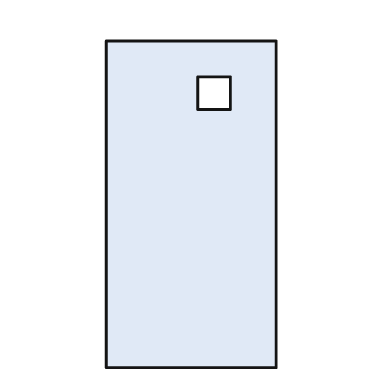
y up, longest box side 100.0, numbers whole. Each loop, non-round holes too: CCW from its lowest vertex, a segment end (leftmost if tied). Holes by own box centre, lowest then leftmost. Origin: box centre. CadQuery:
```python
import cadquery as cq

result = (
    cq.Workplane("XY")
    .moveTo(-26.0, -50.0)
    .lineTo(26.0, -50.0)
    .lineTo(26.0, 50.0)
    .lineTo(-26.0, 50.0)
    .close()
    .moveTo(2.0, 29.0)
    .lineTo(12.0, 29.0)
    .lineTo(12.0, 39.0)
    .lineTo(2.0, 39.0)
    .close()
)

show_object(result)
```